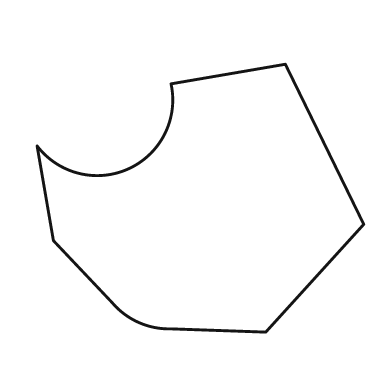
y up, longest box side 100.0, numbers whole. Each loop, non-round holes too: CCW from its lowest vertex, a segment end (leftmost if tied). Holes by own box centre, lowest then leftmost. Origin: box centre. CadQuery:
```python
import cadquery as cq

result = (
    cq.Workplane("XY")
    .moveTo(20.0, -41.0)
    .lineTo(50.0, -8.0)
    .lineTo(26.0, 41.0)
    .lineTo(-9.0, 35.0)
    .threePointArc((-22.0, 9.0), (-50.0, 16.0))
    .lineTo(-45.0, -13.0)
    .lineTo(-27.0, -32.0)
    .threePointArc((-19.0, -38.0), (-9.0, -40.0))
    .close()
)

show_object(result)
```